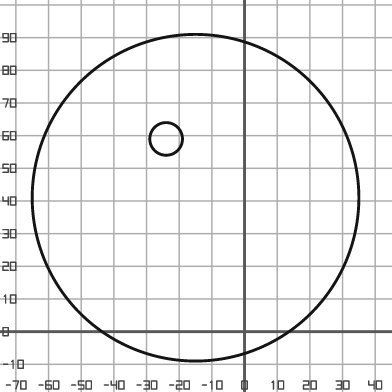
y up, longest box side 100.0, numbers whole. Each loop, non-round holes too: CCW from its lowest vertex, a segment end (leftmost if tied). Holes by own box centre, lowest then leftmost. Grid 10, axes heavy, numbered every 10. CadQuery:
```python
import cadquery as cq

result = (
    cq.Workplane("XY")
    .moveTo(-15.0, 41.0)
    .circle(50.0)
    .moveTo(-24.0, 59.0)
    .circle(5.0)
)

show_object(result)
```